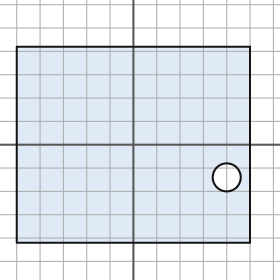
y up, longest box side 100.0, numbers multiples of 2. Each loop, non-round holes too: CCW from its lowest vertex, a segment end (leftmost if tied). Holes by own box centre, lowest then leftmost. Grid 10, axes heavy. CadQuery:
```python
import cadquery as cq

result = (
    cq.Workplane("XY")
    .moveTo(-50.0, -42.0)
    .lineTo(50.0, -42.0)
    .lineTo(50.0, 42.0)
    .lineTo(-50.0, 42.0)
    .close()
    .moveTo(40.0, -14.0)
    .circle(6.0)
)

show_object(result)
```